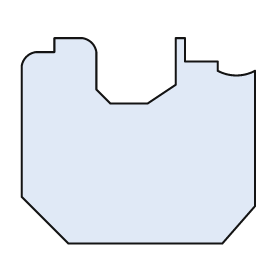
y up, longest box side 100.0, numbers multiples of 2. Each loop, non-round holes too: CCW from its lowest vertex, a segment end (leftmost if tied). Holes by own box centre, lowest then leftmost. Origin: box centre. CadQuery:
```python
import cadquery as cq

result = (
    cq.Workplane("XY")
    .moveTo(-30.0, -44.0)
    .lineTo(36.0, -44.0)
    .lineTo(50.0, -28.0)
    .lineTo(50.0, 30.0)
    .threePointArc((42.0, 28.0), (34.0, 30.0))
    .lineTo(34.0, 34.0)
    .lineTo(20.0, 34.0)
    .lineTo(20.0, 44.0)
    .lineTo(16.0, 44.0)
    .lineTo(16.0, 24.0)
    .lineTo(4.0, 16.0)
    .lineTo(-12.0, 16.0)
    .lineTo(-18.0, 22.0)
    .lineTo(-18.0, 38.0)
    .threePointArc((-20.0, 42.0), (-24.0, 44.0))
    .lineTo(-36.0, 44.0)
    .lineTo(-36.0, 38.0)
    .lineTo(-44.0, 38.0)
    .threePointArc((-48.0, 36.0), (-50.0, 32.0))
    .lineTo(-50.0, -24.0)
    .close()
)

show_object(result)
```